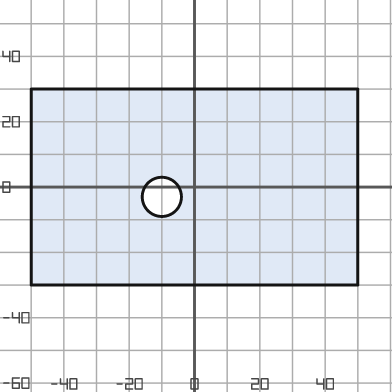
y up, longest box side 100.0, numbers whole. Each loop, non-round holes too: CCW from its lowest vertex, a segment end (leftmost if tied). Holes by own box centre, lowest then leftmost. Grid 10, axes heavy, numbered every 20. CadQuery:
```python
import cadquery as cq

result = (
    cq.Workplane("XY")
    .moveTo(-50.0, -30.0)
    .lineTo(50.0, -30.0)
    .lineTo(50.0, 30.0)
    .lineTo(-50.0, 30.0)
    .close()
    .moveTo(-10.0, -3.0)
    .circle(6.0)
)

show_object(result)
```